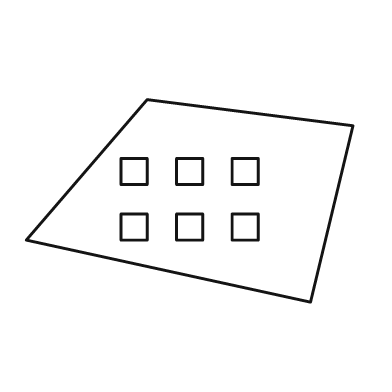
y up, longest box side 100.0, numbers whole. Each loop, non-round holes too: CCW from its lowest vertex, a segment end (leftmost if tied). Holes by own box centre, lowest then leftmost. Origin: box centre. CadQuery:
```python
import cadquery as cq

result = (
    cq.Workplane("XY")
    .moveTo(37.0, -31.0)
    .lineTo(50.0, 23.0)
    .lineTo(-13.0, 31.0)
    .lineTo(-50.0, -12.0)
    .close()
    .moveTo(-21.0, -12.0)
    .lineTo(-13.0, -12.0)
    .lineTo(-13.0, -4.0)
    .lineTo(-21.0, -4.0)
    .close()
    .moveTo(-4.0, -12.0)
    .lineTo(4.0, -12.0)
    .lineTo(4.0, -4.0)
    .lineTo(-4.0, -4.0)
    .close()
    .moveTo(13.0, -12.0)
    .lineTo(21.0, -12.0)
    .lineTo(21.0, -4.0)
    .lineTo(13.0, -4.0)
    .close()
    .moveTo(-21.0, 5.0)
    .lineTo(-13.0, 5.0)
    .lineTo(-13.0, 13.0)
    .lineTo(-21.0, 13.0)
    .close()
    .moveTo(-4.0, 5.0)
    .lineTo(4.0, 5.0)
    .lineTo(4.0, 13.0)
    .lineTo(-4.0, 13.0)
    .close()
    .moveTo(13.0, 5.0)
    .lineTo(21.0, 5.0)
    .lineTo(21.0, 13.0)
    .lineTo(13.0, 13.0)
    .close()
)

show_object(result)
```